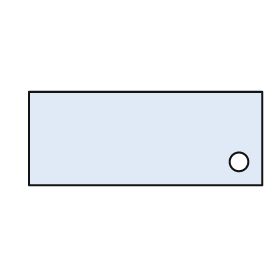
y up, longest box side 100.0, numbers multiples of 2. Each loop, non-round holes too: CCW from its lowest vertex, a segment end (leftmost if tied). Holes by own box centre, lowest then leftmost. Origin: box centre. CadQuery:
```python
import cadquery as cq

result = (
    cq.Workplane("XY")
    .moveTo(-50.0, -20.0)
    .lineTo(50.0, -20.0)
    .lineTo(50.0, 20.0)
    .lineTo(-50.0, 20.0)
    .close()
    .moveTo(40.0, -10.0)
    .circle(4.0)
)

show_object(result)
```